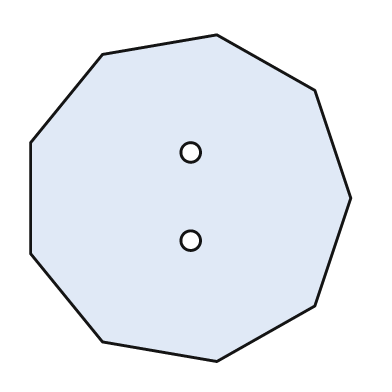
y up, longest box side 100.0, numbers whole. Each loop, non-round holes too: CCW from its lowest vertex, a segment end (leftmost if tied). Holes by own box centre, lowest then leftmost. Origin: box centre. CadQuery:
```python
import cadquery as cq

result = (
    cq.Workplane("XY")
    .moveTo(8.0, -50.0)
    .lineTo(38.0, -33.0)
    .lineTo(49.0, 0.0)
    .lineTo(38.0, 33.0)
    .lineTo(8.0, 50.0)
    .lineTo(-27.0, 44.0)
    .lineTo(-49.0, 17.0)
    .lineTo(-49.0, -17.0)
    .lineTo(-27.0, -44.0)
    .close()
    .moveTo(0.0, -13.0)
    .circle(3.0)
    .moveTo(0.0, 14.0)
    .circle(3.0)
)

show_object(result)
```